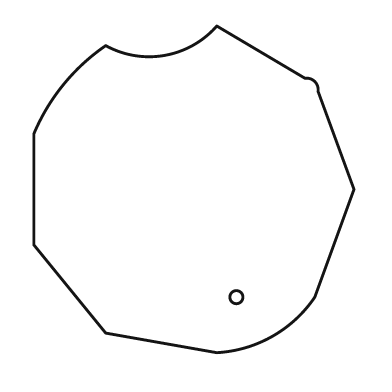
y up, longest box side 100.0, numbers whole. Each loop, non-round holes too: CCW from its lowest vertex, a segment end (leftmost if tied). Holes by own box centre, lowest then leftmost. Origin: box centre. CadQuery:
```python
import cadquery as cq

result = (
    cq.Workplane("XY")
    .moveTo(7.0, -50.0)
    .threePointArc((24.0, -45.0), (37.0, -33.0))
    .lineTo(49.0, 0.0)
    .lineTo(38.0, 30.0)
    .threePointArc((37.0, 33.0), (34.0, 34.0))
    .lineTo(7.0, 50.0)
    .threePointArc((-9.0, 41.0), (-27.0, 44.0))
    .threePointArc((-40.0, 32.0), (-49.0, 17.0))
    .lineTo(-49.0, -17.0)
    .lineTo(-27.0, -44.0)
    .close()
    .moveTo(13.0, -33.0)
    .circle(2.0)
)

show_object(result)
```